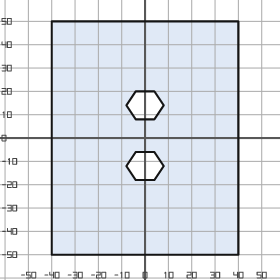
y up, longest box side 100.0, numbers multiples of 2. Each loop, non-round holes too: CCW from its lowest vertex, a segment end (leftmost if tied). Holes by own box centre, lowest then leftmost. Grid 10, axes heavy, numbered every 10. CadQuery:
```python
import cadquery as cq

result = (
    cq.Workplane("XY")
    .moveTo(-40.0, -50.0)
    .lineTo(40.0, -50.0)
    .lineTo(40.0, 50.0)
    .lineTo(-40.0, 50.0)
    .close()
    .moveTo(-4.0, -18.0)
    .lineTo(4.0, -18.0)
    .lineTo(8.0, -12.0)
    .lineTo(4.0, -6.0)
    .lineTo(-4.0, -6.0)
    .lineTo(-8.0, -12.0)
    .close()
    .moveTo(-4.0, 8.0)
    .lineTo(4.0, 8.0)
    .lineTo(8.0, 14.0)
    .lineTo(4.0, 20.0)
    .lineTo(-4.0, 20.0)
    .lineTo(-8.0, 14.0)
    .close()
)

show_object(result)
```